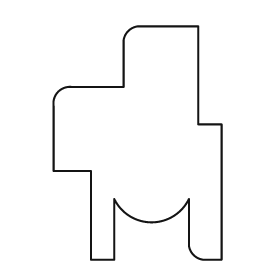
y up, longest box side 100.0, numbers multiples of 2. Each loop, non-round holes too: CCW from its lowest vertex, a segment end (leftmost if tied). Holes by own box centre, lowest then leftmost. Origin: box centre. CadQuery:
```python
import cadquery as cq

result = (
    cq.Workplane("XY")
    .moveTo(-20.0, -50.0)
    .lineTo(-10.0, -50.0)
    .lineTo(-10.0, -24.0)
    .threePointArc((6.0, -34.0), (22.0, -24.0))
    .lineTo(22.0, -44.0)
    .threePointArc((24.0, -48.0), (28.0, -50.0))
    .lineTo(36.0, -50.0)
    .lineTo(36.0, 8.0)
    .lineTo(26.0, 8.0)
    .lineTo(26.0, 50.0)
    .lineTo(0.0, 50.0)
    .threePointArc((-4.0, 48.0), (-6.0, 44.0))
    .lineTo(-6.0, 24.0)
    .lineTo(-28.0, 24.0)
    .threePointArc((-34.0, 22.0), (-36.0, 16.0))
    .lineTo(-36.0, -12.0)
    .lineTo(-20.0, -12.0)
    .close()
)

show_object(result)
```